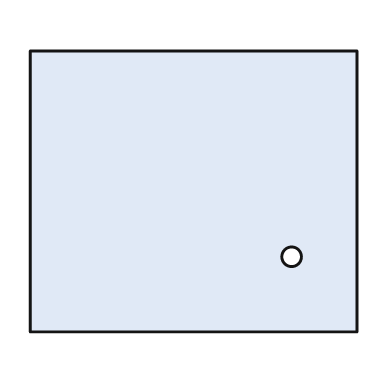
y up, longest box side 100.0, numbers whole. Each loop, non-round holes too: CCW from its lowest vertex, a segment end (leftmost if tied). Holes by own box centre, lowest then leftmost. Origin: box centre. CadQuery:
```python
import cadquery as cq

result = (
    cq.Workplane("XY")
    .moveTo(-50.0, -43.0)
    .lineTo(50.0, -43.0)
    .lineTo(50.0, 43.0)
    .lineTo(-50.0, 43.0)
    .close()
    .moveTo(30.0, -20.0)
    .circle(3.0)
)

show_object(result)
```